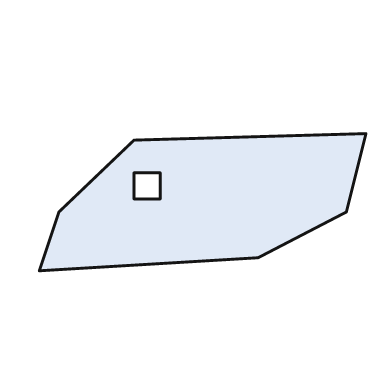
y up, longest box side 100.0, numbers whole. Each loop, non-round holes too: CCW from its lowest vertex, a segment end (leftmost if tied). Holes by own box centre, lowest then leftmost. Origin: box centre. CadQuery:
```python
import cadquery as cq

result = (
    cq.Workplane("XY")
    .moveTo(-50.0, -21.0)
    .lineTo(17.0, -17.0)
    .lineTo(44.0, -3.0)
    .lineTo(50.0, 21.0)
    .lineTo(-21.0, 19.0)
    .lineTo(-44.0, -3.0)
    .close()
    .moveTo(-21.0, 1.0)
    .lineTo(-13.0, 1.0)
    .lineTo(-13.0, 9.0)
    .lineTo(-21.0, 9.0)
    .close()
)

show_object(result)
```